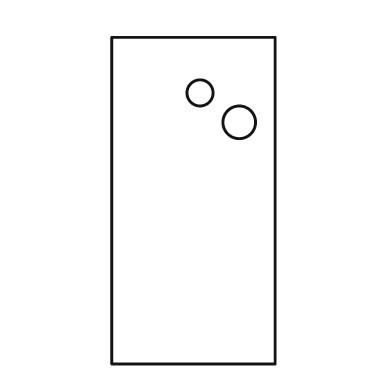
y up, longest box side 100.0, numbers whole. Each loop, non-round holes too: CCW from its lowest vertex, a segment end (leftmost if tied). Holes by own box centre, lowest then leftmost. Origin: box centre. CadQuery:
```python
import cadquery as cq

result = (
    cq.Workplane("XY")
    .moveTo(-25.0, -50.0)
    .lineTo(25.0, -50.0)
    .lineTo(25.0, 50.0)
    .lineTo(-25.0, 50.0)
    .close()
    .moveTo(14.0, 24.0)
    .circle(5.0)
    .moveTo(2.0, 33.0)
    .circle(4.0)
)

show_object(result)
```